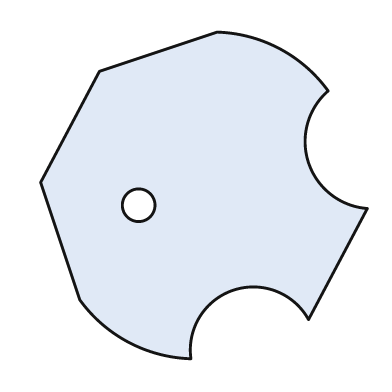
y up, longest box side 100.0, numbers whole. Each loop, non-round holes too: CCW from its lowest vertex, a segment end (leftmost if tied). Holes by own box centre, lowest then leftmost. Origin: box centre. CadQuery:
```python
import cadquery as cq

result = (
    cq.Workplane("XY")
    .moveTo(-4.0, -50.0)
    .threePointArc((9.0, -29.0), (32.0, -38.0))
    .lineTo(50.0, -4.0)
    .threePointArc((32.0, 10.0), (38.0, 32.0))
    .threePointArc((23.0, 45.0), (4.0, 50.0))
    .lineTo(-32.0, 38.0)
    .lineTo(-50.0, 4.0)
    .lineTo(-38.0, -32.0)
    .threePointArc((-23.0, -45.0), (-4.0, -50.0))
    .close()
    .moveTo(-20.0, -3.0)
    .circle(5.0)
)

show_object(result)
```